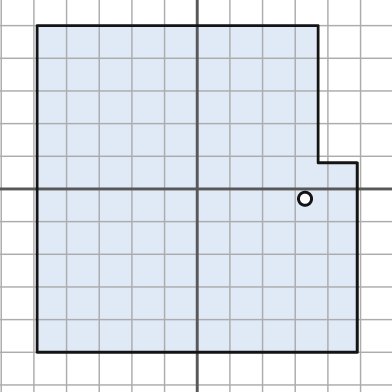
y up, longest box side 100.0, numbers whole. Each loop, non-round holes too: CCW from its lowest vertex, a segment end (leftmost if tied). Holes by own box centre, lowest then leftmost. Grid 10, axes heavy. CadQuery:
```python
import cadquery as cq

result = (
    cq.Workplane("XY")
    .moveTo(-49.0, -50.0)
    .lineTo(49.0, -50.0)
    .lineTo(49.0, 8.0)
    .lineTo(37.0, 8.0)
    .lineTo(37.0, 50.0)
    .lineTo(-49.0, 50.0)
    .close()
    .moveTo(33.0, -3.0)
    .circle(2.0)
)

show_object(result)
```